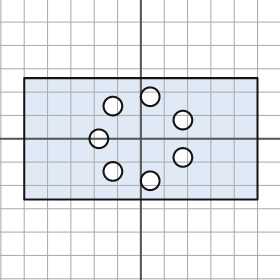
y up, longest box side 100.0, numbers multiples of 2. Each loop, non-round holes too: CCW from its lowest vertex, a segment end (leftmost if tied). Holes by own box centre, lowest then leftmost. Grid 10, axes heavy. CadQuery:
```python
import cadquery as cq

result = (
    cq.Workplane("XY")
    .moveTo(-50.0, -26.0)
    .lineTo(50.0, -26.0)
    .lineTo(50.0, 26.0)
    .lineTo(-50.0, 26.0)
    .close()
    .moveTo(4.0, -18.0)
    .circle(4.0)
    .moveTo(-12.0, -14.0)
    .circle(4.0)
    .moveTo(18.0, -8.0)
    .circle(4.0)
    .moveTo(-18.0, 0.0)
    .circle(4.0)
    .moveTo(18.0, 8.0)
    .circle(4.0)
    .moveTo(-12.0, 14.0)
    .circle(4.0)
    .moveTo(4.0, 18.0)
    .circle(4.0)
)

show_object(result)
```